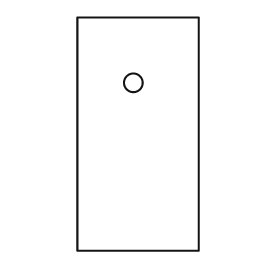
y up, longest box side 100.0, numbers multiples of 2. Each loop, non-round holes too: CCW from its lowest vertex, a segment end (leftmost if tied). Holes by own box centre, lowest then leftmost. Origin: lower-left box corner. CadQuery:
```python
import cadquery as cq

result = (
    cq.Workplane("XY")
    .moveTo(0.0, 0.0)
    .lineTo(52.0, 0.0)
    .lineTo(52.0, 100.0)
    .lineTo(0.0, 100.0)
    .close()
    .moveTo(24.0, 72.0)
    .circle(4.0)
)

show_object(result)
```